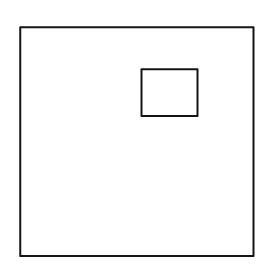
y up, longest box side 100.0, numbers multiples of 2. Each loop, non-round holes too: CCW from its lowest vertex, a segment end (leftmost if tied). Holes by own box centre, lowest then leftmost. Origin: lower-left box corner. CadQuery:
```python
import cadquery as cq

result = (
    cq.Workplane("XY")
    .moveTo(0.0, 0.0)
    .lineTo(100.0, 0.0)
    .lineTo(100.0, 98.0)
    .lineTo(0.0, 98.0)
    .close()
    .moveTo(52.0, 60.0)
    .lineTo(76.0, 60.0)
    .lineTo(76.0, 80.0)
    .lineTo(52.0, 80.0)
    .close()
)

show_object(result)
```